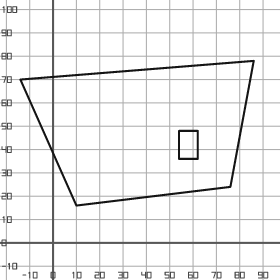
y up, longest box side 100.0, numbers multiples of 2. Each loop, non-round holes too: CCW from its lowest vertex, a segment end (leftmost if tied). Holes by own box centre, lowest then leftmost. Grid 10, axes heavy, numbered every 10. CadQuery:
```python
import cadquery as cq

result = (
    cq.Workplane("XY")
    .moveTo(10.0, 16.0)
    .lineTo(76.0, 24.0)
    .lineTo(86.0, 78.0)
    .lineTo(-14.0, 70.0)
    .close()
    .moveTo(54.0, 36.0)
    .lineTo(62.0, 36.0)
    .lineTo(62.0, 48.0)
    .lineTo(54.0, 48.0)
    .close()
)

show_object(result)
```